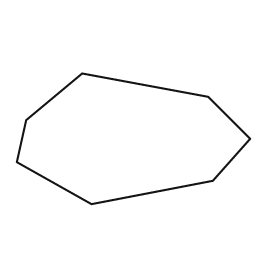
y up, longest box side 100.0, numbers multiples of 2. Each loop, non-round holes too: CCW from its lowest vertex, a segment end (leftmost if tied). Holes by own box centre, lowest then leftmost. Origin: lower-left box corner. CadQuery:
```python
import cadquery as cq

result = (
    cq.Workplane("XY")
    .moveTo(32.0, 0.0)
    .lineTo(84.0, 10.0)
    .lineTo(100.0, 28.0)
    .lineTo(82.0, 46.0)
    .lineTo(28.0, 56.0)
    .lineTo(4.0, 36.0)
    .lineTo(0.0, 18.0)
    .close()
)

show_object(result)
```